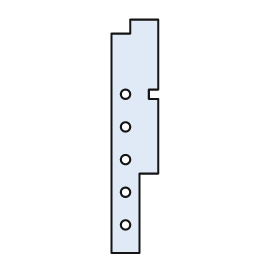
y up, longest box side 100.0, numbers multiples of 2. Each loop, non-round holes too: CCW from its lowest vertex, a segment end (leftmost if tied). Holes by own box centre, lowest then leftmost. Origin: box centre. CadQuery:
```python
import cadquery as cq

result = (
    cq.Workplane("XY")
    .moveTo(-10.0, -50.0)
    .lineTo(2.0, -50.0)
    .lineTo(2.0, -16.0)
    .lineTo(10.0, -16.0)
    .lineTo(10.0, 16.0)
    .lineTo(6.0, 16.0)
    .lineTo(6.0, 20.0)
    .lineTo(10.0, 20.0)
    .lineTo(10.0, 50.0)
    .lineTo(-2.0, 50.0)
    .lineTo(-2.0, 44.0)
    .lineTo(-10.0, 44.0)
    .close()
    .moveTo(-4.0, -38.0)
    .circle(2.0)
    .moveTo(-4.0, -24.0)
    .circle(2.0)
    .moveTo(-4.0, -10.0)
    .circle(2.0)
    .moveTo(-4.0, 4.0)
    .circle(2.0)
    .moveTo(-4.0, 18.0)
    .circle(2.0)
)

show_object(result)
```